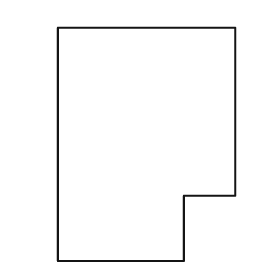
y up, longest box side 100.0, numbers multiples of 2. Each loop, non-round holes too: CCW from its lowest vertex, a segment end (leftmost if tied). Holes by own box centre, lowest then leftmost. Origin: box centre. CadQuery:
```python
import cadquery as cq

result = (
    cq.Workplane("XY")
    .moveTo(-38.0, -50.0)
    .lineTo(16.0, -50.0)
    .lineTo(16.0, -22.0)
    .lineTo(38.0, -22.0)
    .lineTo(38.0, 50.0)
    .lineTo(-38.0, 50.0)
    .close()
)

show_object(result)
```